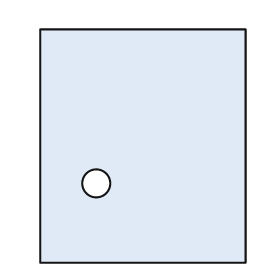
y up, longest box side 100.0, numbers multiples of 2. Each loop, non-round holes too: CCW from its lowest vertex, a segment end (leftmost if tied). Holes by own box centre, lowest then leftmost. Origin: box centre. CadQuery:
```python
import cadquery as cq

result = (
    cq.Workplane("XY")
    .moveTo(-44.0, -50.0)
    .lineTo(44.0, -50.0)
    .lineTo(44.0, 50.0)
    .lineTo(-44.0, 50.0)
    .close()
    .moveTo(-20.0, -16.0)
    .circle(6.0)
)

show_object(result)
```